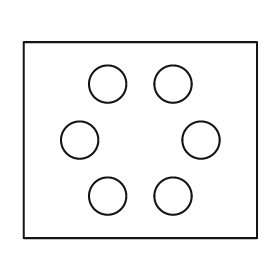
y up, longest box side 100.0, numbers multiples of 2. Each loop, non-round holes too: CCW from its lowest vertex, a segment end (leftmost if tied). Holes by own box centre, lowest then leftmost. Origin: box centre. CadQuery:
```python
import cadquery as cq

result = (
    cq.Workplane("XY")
    .moveTo(-50.0, -42.0)
    .lineTo(50.0, -42.0)
    .lineTo(50.0, 42.0)
    .lineTo(-50.0, 42.0)
    .close()
    .moveTo(-14.0, -24.0)
    .circle(8.0)
    .moveTo(14.0, -24.0)
    .circle(8.0)
    .moveTo(-26.0, 0.0)
    .circle(8.0)
    .moveTo(26.0, 0.0)
    .circle(8.0)
    .moveTo(-14.0, 24.0)
    .circle(8.0)
    .moveTo(14.0, 24.0)
    .circle(8.0)
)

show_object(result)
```